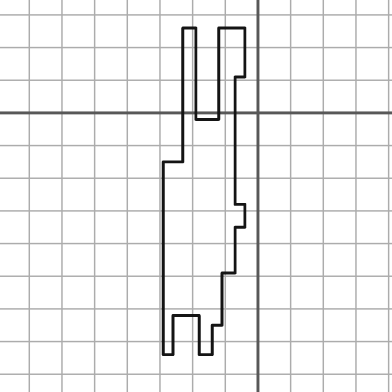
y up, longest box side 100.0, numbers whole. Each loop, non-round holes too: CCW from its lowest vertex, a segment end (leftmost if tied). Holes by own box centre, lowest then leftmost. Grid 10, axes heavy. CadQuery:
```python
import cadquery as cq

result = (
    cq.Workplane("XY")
    .moveTo(-29.0, -74.0)
    .lineTo(-26.0, -74.0)
    .lineTo(-26.0, -62.0)
    .lineTo(-18.0, -62.0)
    .lineTo(-18.0, -74.0)
    .lineTo(-14.0, -74.0)
    .lineTo(-14.0, -65.0)
    .lineTo(-11.0, -65.0)
    .lineTo(-11.0, -49.0)
    .lineTo(-7.0, -49.0)
    .lineTo(-7.0, -35.0)
    .lineTo(-4.0, -35.0)
    .lineTo(-4.0, -28.0)
    .lineTo(-7.0, -28.0)
    .lineTo(-7.0, 11.0)
    .lineTo(-4.0, 11.0)
    .lineTo(-4.0, 26.0)
    .lineTo(-12.0, 26.0)
    .lineTo(-12.0, -2.0)
    .lineTo(-19.0, -2.0)
    .lineTo(-19.0, 26.0)
    .lineTo(-23.0, 26.0)
    .lineTo(-23.0, -15.0)
    .lineTo(-29.0, -15.0)
    .close()
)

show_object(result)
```